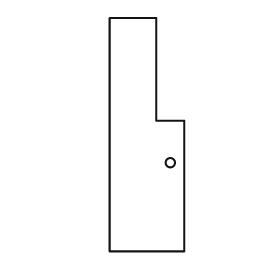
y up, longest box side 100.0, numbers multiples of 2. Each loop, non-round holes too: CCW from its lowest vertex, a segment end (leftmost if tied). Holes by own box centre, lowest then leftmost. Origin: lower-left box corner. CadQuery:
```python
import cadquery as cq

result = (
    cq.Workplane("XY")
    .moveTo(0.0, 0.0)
    .lineTo(32.0, 0.0)
    .lineTo(32.0, 56.0)
    .lineTo(20.0, 56.0)
    .lineTo(20.0, 100.0)
    .lineTo(0.0, 100.0)
    .close()
    .moveTo(26.0, 38.0)
    .circle(2.0)
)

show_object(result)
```